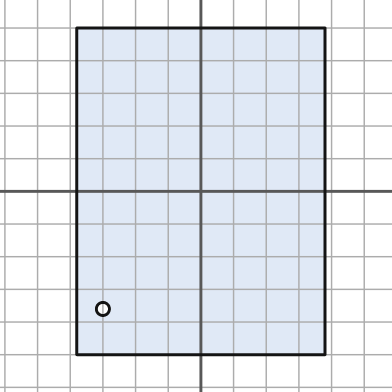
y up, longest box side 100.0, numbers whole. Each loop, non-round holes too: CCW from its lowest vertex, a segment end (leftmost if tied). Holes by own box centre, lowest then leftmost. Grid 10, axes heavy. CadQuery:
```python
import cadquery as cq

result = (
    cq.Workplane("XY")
    .moveTo(-38.0, -50.0)
    .lineTo(38.0, -50.0)
    .lineTo(38.0, 50.0)
    .lineTo(-38.0, 50.0)
    .close()
    .moveTo(-30.0, -36.0)
    .circle(2.0)
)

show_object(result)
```